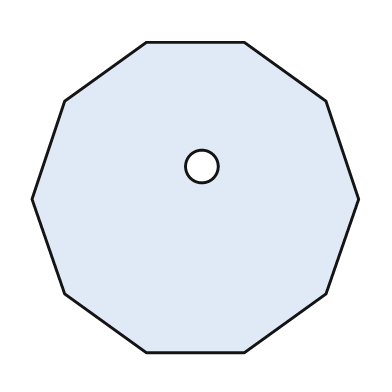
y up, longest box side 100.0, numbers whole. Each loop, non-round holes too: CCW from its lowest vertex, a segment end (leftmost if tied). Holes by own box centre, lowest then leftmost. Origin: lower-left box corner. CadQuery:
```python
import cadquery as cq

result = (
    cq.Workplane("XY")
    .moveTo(35.0, 0.0)
    .lineTo(65.0, 0.0)
    .lineTo(90.0, 18.0)
    .lineTo(100.0, 47.0)
    .lineTo(90.0, 77.0)
    .lineTo(65.0, 95.0)
    .lineTo(35.0, 95.0)
    .lineTo(10.0, 77.0)
    .lineTo(0.0, 47.0)
    .lineTo(10.0, 18.0)
    .close()
    .moveTo(52.0, 57.0)
    .circle(5.0)
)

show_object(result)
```